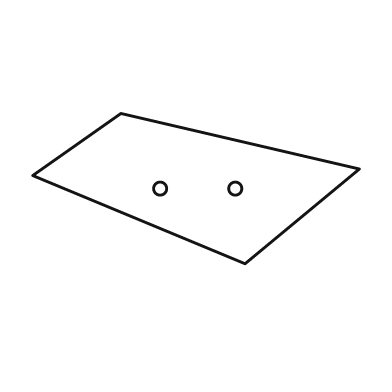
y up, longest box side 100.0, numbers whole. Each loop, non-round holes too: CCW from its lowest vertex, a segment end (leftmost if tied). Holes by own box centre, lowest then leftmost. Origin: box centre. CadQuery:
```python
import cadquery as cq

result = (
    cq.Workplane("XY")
    .moveTo(15.0, -23.0)
    .lineTo(50.0, 6.0)
    .lineTo(-23.0, 23.0)
    .lineTo(-50.0, 4.0)
    .close()
    .moveTo(-11.0, 0.0)
    .circle(2.0)
    .moveTo(12.0, 0.0)
    .circle(2.0)
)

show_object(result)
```